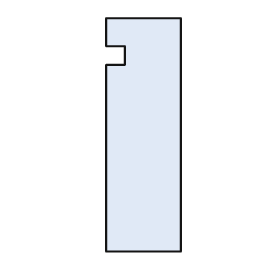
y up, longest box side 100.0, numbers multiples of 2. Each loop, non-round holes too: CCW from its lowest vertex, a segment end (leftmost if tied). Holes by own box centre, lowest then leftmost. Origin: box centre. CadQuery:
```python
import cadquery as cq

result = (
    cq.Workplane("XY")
    .moveTo(-16.0, -50.0)
    .lineTo(16.0, -50.0)
    .lineTo(16.0, 50.0)
    .lineTo(-16.0, 50.0)
    .lineTo(-16.0, 38.0)
    .lineTo(-8.0, 38.0)
    .lineTo(-8.0, 30.0)
    .lineTo(-16.0, 30.0)
    .close()
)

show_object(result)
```